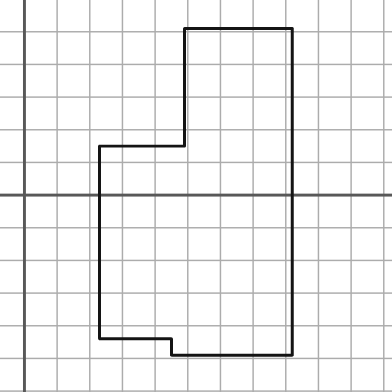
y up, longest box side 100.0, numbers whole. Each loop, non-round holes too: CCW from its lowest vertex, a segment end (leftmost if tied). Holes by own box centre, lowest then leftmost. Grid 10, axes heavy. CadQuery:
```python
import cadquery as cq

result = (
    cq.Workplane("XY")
    .moveTo(45.0, -49.0)
    .lineTo(82.0, -49.0)
    .lineTo(82.0, 51.0)
    .lineTo(49.0, 51.0)
    .lineTo(49.0, 15.0)
    .lineTo(23.0, 15.0)
    .lineTo(23.0, -44.0)
    .lineTo(45.0, -44.0)
    .close()
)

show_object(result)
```